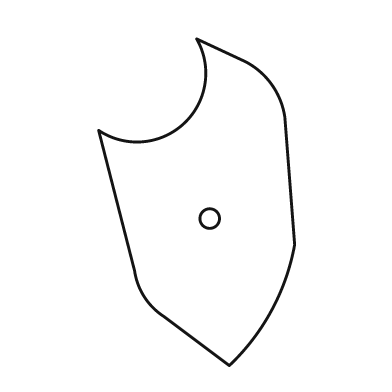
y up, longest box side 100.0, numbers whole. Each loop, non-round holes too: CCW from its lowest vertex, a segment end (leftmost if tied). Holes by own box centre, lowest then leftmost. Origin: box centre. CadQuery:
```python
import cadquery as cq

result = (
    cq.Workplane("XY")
    .moveTo(10.0, -50.0)
    .threePointArc((23.0, -33.0), (30.0, -13.0))
    .lineTo(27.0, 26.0)
    .threePointArc((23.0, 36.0), (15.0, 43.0))
    .lineTo(0.0, 50.0)
    .threePointArc((-4.0, 24.0), (-30.0, 22.0))
    .lineTo(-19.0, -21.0)
    .threePointArc((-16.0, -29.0), (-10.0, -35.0))
    .close()
    .moveTo(4.0, -5.0)
    .circle(3.0)
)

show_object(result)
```